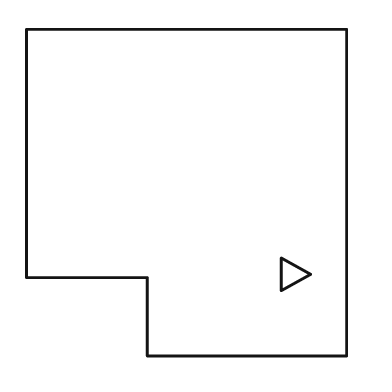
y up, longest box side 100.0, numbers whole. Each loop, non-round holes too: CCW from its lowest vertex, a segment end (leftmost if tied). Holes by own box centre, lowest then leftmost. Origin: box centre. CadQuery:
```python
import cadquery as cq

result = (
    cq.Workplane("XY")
    .moveTo(-12.0, -50.0)
    .lineTo(49.0, -50.0)
    .lineTo(49.0, 50.0)
    .lineTo(-49.0, 50.0)
    .lineTo(-49.0, -26.0)
    .lineTo(-12.0, -26.0)
    .close()
    .moveTo(29.0, -30.0)
    .lineTo(38.0, -25.0)
    .lineTo(29.0, -20.0)
    .close()
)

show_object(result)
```